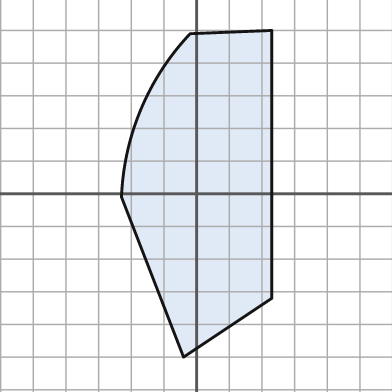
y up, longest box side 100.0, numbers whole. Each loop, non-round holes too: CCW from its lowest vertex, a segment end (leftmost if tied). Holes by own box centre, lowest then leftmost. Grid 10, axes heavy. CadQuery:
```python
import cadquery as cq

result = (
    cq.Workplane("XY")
    .moveTo(-4.0, -50.0)
    .lineTo(23.0, -32.0)
    .lineTo(23.0, 50.0)
    .lineTo(-2.0, 49.0)
    .threePointArc((-17.0, 26.0), (-23.0, -1.0))
    .close()
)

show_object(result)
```